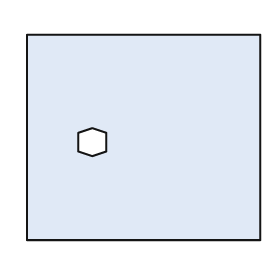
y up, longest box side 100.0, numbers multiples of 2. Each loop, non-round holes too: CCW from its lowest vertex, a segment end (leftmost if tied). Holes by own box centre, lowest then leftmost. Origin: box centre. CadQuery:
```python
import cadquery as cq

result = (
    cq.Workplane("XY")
    .moveTo(-50.0, -44.0)
    .lineTo(50.0, -44.0)
    .lineTo(50.0, 44.0)
    .lineTo(-50.0, 44.0)
    .close()
    .moveTo(-22.0, -8.0)
    .lineTo(-16.0, -6.0)
    .lineTo(-16.0, 2.0)
    .lineTo(-22.0, 4.0)
    .lineTo(-28.0, 2.0)
    .lineTo(-28.0, -6.0)
    .close()
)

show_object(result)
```